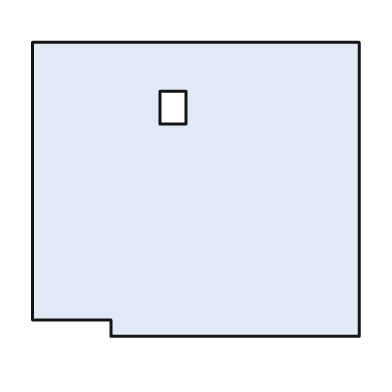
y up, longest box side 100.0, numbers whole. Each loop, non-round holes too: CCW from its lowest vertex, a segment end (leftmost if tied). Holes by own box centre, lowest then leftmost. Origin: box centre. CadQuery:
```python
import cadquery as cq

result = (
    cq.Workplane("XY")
    .moveTo(-26.0, -45.0)
    .lineTo(50.0, -45.0)
    .lineTo(50.0, 45.0)
    .lineTo(-50.0, 45.0)
    .lineTo(-50.0, -40.0)
    .lineTo(-26.0, -40.0)
    .close()
    .moveTo(-11.0, 20.0)
    .lineTo(-3.0, 20.0)
    .lineTo(-3.0, 30.0)
    .lineTo(-11.0, 30.0)
    .close()
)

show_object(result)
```